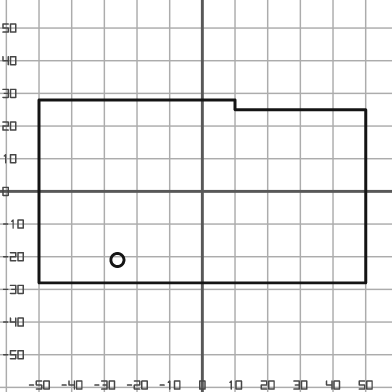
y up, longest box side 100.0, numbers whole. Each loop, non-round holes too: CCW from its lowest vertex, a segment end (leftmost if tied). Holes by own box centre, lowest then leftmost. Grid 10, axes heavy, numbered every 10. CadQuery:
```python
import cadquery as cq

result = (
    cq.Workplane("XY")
    .moveTo(-50.0, -28.0)
    .lineTo(50.0, -28.0)
    .lineTo(50.0, 25.0)
    .lineTo(10.0, 25.0)
    .lineTo(10.0, 28.0)
    .lineTo(-50.0, 28.0)
    .close()
    .moveTo(-26.0, -21.0)
    .circle(2.0)
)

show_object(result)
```